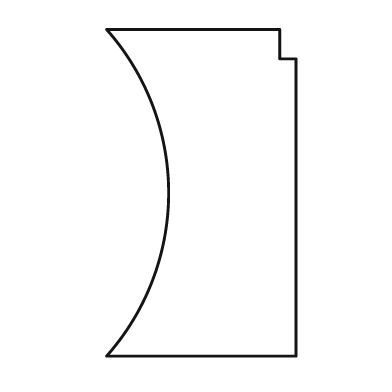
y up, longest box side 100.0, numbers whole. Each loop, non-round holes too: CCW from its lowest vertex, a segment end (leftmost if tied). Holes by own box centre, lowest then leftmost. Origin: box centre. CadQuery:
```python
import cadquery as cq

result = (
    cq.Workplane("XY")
    .moveTo(-29.0, -50.0)
    .lineTo(29.0, -50.0)
    .lineTo(29.0, 41.0)
    .lineTo(24.0, 41.0)
    .lineTo(24.0, 50.0)
    .lineTo(-29.0, 50.0)
    .threePointArc((-10.0, 0.0), (-29.0, -50.0))
    .close()
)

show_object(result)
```